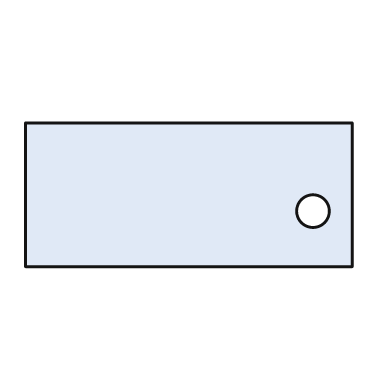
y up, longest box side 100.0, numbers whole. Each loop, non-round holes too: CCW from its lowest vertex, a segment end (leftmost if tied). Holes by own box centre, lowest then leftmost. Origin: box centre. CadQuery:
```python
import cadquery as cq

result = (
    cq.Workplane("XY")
    .moveTo(-50.0, -22.0)
    .lineTo(50.0, -22.0)
    .lineTo(50.0, 22.0)
    .lineTo(-50.0, 22.0)
    .close()
    .moveTo(38.0, -5.0)
    .circle(5.0)
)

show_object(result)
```